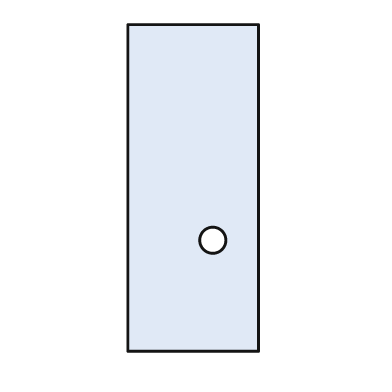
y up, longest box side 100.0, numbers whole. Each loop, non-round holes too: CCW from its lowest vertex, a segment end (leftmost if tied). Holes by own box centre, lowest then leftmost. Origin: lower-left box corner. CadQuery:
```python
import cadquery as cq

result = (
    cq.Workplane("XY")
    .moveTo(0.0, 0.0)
    .lineTo(40.0, 0.0)
    .lineTo(40.0, 100.0)
    .lineTo(0.0, 100.0)
    .close()
    .moveTo(26.0, 34.0)
    .circle(4.0)
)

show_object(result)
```